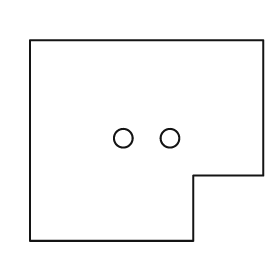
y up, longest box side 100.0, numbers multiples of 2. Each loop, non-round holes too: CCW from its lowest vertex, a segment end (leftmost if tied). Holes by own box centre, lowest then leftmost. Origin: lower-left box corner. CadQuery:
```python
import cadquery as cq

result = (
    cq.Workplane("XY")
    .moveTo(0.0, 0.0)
    .lineTo(70.0, 0.0)
    .lineTo(70.0, 28.0)
    .lineTo(100.0, 28.0)
    .lineTo(100.0, 86.0)
    .lineTo(0.0, 86.0)
    .close()
    .moveTo(40.0, 44.0)
    .circle(4.0)
    .moveTo(60.0, 44.0)
    .circle(4.0)
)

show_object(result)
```